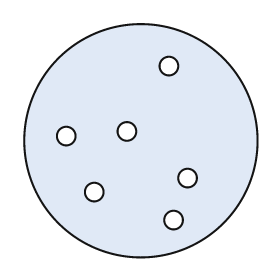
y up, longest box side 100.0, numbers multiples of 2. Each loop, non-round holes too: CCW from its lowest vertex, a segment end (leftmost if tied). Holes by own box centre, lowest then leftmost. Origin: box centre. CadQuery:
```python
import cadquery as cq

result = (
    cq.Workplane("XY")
    .moveTo(0.0, 0.0)
    .circle(50.0)
    .moveTo(14.0, -34.0)
    .circle(4.0)
    .moveTo(-20.0, -22.0)
    .circle(4.0)
    .moveTo(20.0, -16.0)
    .circle(4.0)
    .moveTo(-32.0, 2.0)
    .circle(4.0)
    .moveTo(-6.0, 4.0)
    .circle(4.0)
    .moveTo(12.0, 32.0)
    .circle(4.0)
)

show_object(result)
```